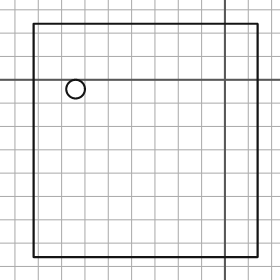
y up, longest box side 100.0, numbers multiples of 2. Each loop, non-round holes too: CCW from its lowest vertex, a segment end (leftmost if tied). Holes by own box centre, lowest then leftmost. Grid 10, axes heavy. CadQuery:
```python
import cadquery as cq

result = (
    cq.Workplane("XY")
    .moveTo(-82.0, -76.0)
    .lineTo(14.0, -76.0)
    .lineTo(14.0, 24.0)
    .lineTo(-82.0, 24.0)
    .close()
    .moveTo(-64.0, -4.0)
    .circle(4.0)
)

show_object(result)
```